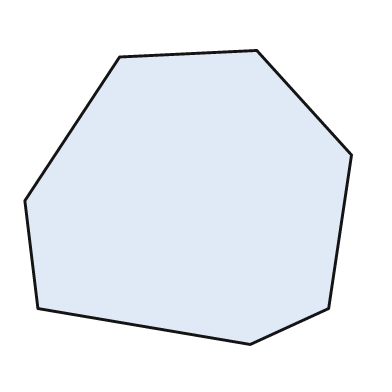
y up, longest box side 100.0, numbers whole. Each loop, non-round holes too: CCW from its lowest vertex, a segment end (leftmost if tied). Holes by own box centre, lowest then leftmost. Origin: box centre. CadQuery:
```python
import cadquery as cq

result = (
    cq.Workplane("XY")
    .moveTo(19.0, -45.0)
    .lineTo(43.0, -34.0)
    .lineTo(50.0, 13.0)
    .lineTo(21.0, 45.0)
    .lineTo(-21.0, 43.0)
    .lineTo(-50.0, -1.0)
    .lineTo(-46.0, -34.0)
    .close()
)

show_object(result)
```